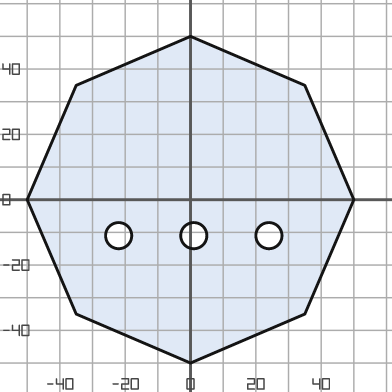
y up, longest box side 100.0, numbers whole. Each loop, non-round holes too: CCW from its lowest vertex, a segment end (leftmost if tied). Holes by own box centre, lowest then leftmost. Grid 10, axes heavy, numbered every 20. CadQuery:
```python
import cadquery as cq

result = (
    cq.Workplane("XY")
    .moveTo(0.0, -50.0)
    .lineTo(35.0, -35.0)
    .lineTo(50.0, 0.0)
    .lineTo(35.0, 35.0)
    .lineTo(0.0, 50.0)
    .lineTo(-35.0, 35.0)
    .lineTo(-50.0, 0.0)
    .lineTo(-35.0, -35.0)
    .close()
    .moveTo(-22.0, -11.0)
    .circle(4.0)
    .moveTo(1.0, -11.0)
    .circle(4.0)
    .moveTo(24.0, -11.0)
    .circle(4.0)
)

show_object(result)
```